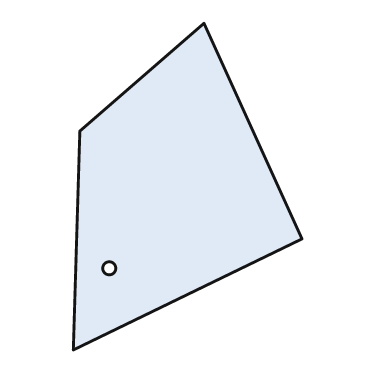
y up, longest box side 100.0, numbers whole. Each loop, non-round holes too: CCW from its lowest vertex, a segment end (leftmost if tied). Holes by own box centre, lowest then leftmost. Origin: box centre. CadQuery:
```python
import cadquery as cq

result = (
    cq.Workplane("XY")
    .moveTo(-35.0, -50.0)
    .lineTo(35.0, -16.0)
    .lineTo(5.0, 50.0)
    .lineTo(-33.0, 17.0)
    .close()
    .moveTo(-24.0, -25.0)
    .circle(2.0)
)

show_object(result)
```